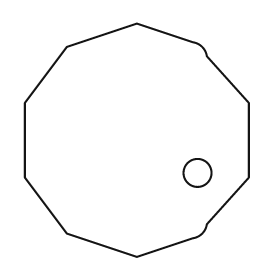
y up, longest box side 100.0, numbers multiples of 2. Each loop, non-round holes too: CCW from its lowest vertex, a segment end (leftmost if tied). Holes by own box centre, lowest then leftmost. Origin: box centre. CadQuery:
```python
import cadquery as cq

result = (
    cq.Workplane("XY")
    .moveTo(0.0, -50.0)
    .lineTo(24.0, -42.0)
    .threePointArc((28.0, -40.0), (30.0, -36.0))
    .lineTo(48.0, -16.0)
    .lineTo(48.0, 16.0)
    .lineTo(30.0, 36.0)
    .threePointArc((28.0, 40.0), (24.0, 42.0))
    .lineTo(0.0, 50.0)
    .lineTo(-30.0, 40.0)
    .lineTo(-48.0, 16.0)
    .lineTo(-48.0, -16.0)
    .lineTo(-30.0, -40.0)
    .close()
    .moveTo(26.0, -14.0)
    .circle(6.0)
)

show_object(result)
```